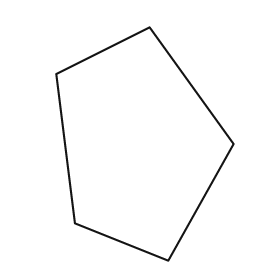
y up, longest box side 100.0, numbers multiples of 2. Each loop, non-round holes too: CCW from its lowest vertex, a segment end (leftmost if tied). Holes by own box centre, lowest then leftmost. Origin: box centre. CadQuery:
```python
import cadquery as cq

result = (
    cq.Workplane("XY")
    .moveTo(10.0, -50.0)
    .lineTo(38.0, 0.0)
    .lineTo(2.0, 50.0)
    .lineTo(-38.0, 30.0)
    .lineTo(-30.0, -34.0)
    .close()
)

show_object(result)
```